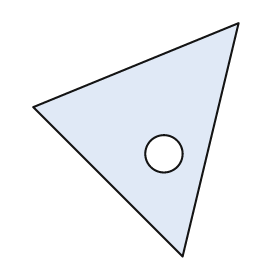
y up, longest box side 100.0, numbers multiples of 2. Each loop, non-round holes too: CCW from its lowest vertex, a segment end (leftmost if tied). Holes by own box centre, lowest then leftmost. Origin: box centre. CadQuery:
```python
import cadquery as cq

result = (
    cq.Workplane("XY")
    .moveTo(20.0, -50.0)
    .lineTo(44.0, 50.0)
    .lineTo(-44.0, 14.0)
    .close()
    .moveTo(12.0, -6.0)
    .circle(8.0)
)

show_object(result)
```